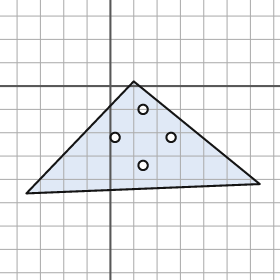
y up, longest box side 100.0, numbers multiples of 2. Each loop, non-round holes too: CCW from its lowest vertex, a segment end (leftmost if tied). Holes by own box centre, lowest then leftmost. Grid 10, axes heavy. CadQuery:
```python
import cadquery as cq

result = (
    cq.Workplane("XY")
    .moveTo(-36.0, -46.0)
    .lineTo(64.0, -42.0)
    .lineTo(10.0, 2.0)
    .close()
    .moveTo(14.0, -34.0)
    .circle(2.0)
    .moveTo(2.0, -22.0)
    .circle(2.0)
    .moveTo(26.0, -22.0)
    .circle(2.0)
    .moveTo(14.0, -10.0)
    .circle(2.0)
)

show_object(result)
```